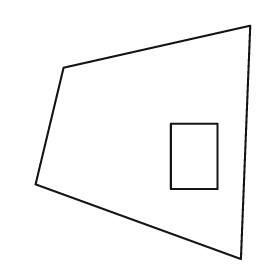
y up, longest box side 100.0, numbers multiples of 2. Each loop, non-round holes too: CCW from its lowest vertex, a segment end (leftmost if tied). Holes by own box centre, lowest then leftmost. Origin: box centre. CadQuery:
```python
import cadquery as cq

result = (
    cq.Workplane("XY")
    .moveTo(42.0, -50.0)
    .lineTo(46.0, 50.0)
    .lineTo(-34.0, 32.0)
    .lineTo(-46.0, -18.0)
    .close()
    .moveTo(12.0, -20.0)
    .lineTo(32.0, -20.0)
    .lineTo(32.0, 8.0)
    .lineTo(12.0, 8.0)
    .close()
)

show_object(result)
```